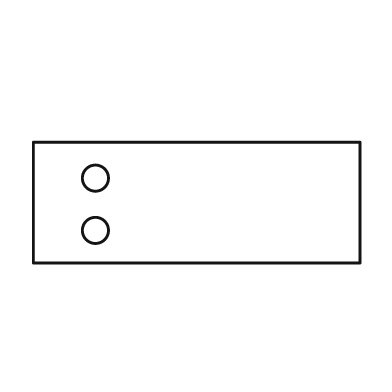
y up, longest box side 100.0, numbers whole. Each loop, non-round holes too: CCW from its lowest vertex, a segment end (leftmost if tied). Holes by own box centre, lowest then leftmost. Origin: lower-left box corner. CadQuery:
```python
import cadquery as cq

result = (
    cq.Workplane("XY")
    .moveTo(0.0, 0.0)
    .lineTo(100.0, 0.0)
    .lineTo(100.0, 37.0)
    .lineTo(0.0, 37.0)
    .close()
    .moveTo(19.0, 10.0)
    .circle(4.0)
    .moveTo(19.0, 26.0)
    .circle(4.0)
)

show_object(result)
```